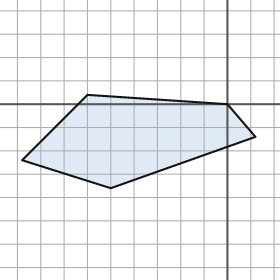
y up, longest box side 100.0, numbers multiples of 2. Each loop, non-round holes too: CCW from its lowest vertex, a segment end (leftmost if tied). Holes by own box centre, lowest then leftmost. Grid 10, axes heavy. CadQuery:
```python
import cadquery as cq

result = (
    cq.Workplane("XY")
    .moveTo(-50.0, -36.0)
    .lineTo(12.0, -14.0)
    .lineTo(0.0, 0.0)
    .lineTo(-60.0, 4.0)
    .lineTo(-88.0, -24.0)
    .close()
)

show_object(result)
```